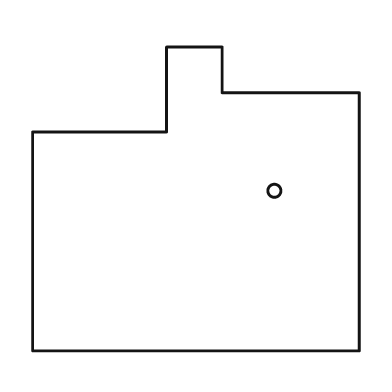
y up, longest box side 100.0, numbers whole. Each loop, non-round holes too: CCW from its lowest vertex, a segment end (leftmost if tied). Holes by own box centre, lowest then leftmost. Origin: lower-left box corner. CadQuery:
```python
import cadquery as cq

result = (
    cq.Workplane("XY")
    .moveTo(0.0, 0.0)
    .lineTo(100.0, 0.0)
    .lineTo(100.0, 79.0)
    .lineTo(58.0, 79.0)
    .lineTo(58.0, 93.0)
    .lineTo(41.0, 93.0)
    .lineTo(41.0, 67.0)
    .lineTo(0.0, 67.0)
    .close()
    .moveTo(74.0, 49.0)
    .circle(2.0)
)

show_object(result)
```